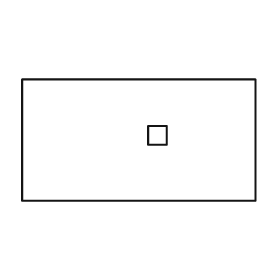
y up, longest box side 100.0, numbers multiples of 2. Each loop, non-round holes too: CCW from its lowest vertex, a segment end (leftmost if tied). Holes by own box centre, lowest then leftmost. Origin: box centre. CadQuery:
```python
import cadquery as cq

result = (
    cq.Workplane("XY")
    .moveTo(-50.0, -26.0)
    .lineTo(50.0, -26.0)
    .lineTo(50.0, 26.0)
    .lineTo(-50.0, 26.0)
    .close()
    .moveTo(4.0, -2.0)
    .lineTo(12.0, -2.0)
    .lineTo(12.0, 6.0)
    .lineTo(4.0, 6.0)
    .close()
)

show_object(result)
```